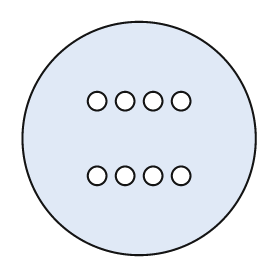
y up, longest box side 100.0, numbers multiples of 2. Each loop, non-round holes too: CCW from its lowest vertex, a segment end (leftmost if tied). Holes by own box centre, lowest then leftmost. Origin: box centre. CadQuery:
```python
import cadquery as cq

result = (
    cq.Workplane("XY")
    .moveTo(0.0, 0.0)
    .circle(50.0)
    .moveTo(-18.0, -16.0)
    .circle(4.0)
    .moveTo(-6.0, -16.0)
    .circle(4.0)
    .moveTo(6.0, -16.0)
    .circle(4.0)
    .moveTo(18.0, -16.0)
    .circle(4.0)
    .moveTo(-18.0, 16.0)
    .circle(4.0)
    .moveTo(-6.0, 16.0)
    .circle(4.0)
    .moveTo(6.0, 16.0)
    .circle(4.0)
    .moveTo(18.0, 16.0)
    .circle(4.0)
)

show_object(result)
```